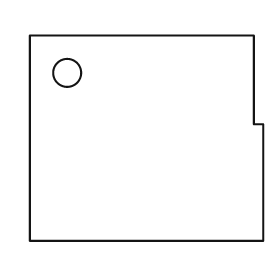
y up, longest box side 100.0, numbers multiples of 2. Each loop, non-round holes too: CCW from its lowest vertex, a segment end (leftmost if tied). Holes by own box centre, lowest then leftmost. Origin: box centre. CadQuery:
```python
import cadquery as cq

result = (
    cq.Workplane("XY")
    .moveTo(-50.0, -44.0)
    .lineTo(50.0, -44.0)
    .lineTo(50.0, 6.0)
    .lineTo(46.0, 6.0)
    .lineTo(46.0, 44.0)
    .lineTo(-50.0, 44.0)
    .close()
    .moveTo(-34.0, 28.0)
    .circle(6.0)
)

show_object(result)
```